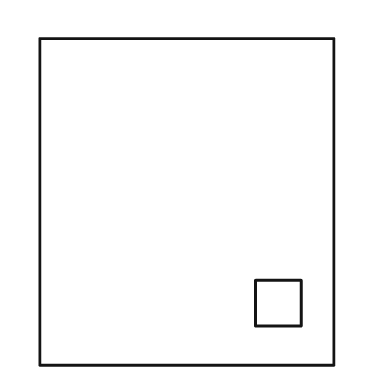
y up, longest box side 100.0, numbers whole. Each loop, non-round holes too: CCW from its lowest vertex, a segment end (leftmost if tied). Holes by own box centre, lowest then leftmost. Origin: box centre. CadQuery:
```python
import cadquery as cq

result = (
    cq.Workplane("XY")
    .moveTo(-45.0, -50.0)
    .lineTo(45.0, -50.0)
    .lineTo(45.0, 50.0)
    .lineTo(-45.0, 50.0)
    .close()
    .moveTo(21.0, -38.0)
    .lineTo(35.0, -38.0)
    .lineTo(35.0, -24.0)
    .lineTo(21.0, -24.0)
    .close()
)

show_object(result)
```